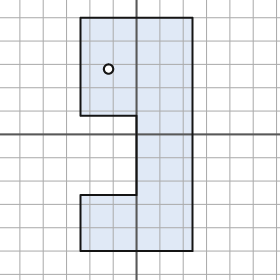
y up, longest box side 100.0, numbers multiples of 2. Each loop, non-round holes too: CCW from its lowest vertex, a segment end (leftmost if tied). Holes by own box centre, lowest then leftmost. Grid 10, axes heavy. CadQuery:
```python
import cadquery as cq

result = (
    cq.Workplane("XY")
    .moveTo(-24.0, -50.0)
    .lineTo(24.0, -50.0)
    .lineTo(24.0, 50.0)
    .lineTo(-24.0, 50.0)
    .lineTo(-24.0, 8.0)
    .lineTo(0.0, 8.0)
    .lineTo(0.0, -26.0)
    .lineTo(-24.0, -26.0)
    .close()
    .moveTo(-12.0, 28.0)
    .circle(2.0)
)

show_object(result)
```